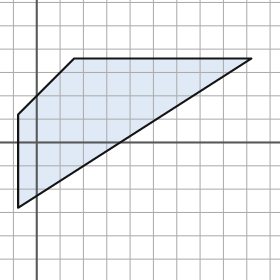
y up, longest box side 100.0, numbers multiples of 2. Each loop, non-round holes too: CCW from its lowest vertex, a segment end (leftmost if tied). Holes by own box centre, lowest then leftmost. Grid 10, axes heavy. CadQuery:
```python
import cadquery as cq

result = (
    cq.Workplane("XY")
    .moveTo(-8.0, -28.0)
    .lineTo(92.0, 36.0)
    .lineTo(16.0, 36.0)
    .lineTo(-8.0, 12.0)
    .close()
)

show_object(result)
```